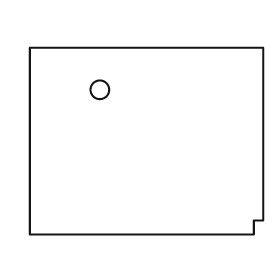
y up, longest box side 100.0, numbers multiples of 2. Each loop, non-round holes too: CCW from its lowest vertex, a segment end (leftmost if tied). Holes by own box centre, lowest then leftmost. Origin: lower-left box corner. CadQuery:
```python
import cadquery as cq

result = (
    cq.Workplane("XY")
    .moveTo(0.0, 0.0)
    .lineTo(96.0, 0.0)
    .lineTo(96.0, 6.0)
    .lineTo(100.0, 6.0)
    .lineTo(100.0, 80.0)
    .lineTo(0.0, 80.0)
    .close()
    .moveTo(30.0, 62.0)
    .circle(4.0)
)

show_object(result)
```